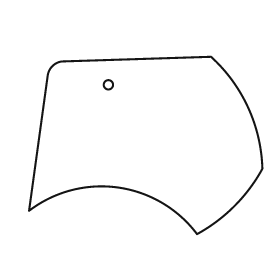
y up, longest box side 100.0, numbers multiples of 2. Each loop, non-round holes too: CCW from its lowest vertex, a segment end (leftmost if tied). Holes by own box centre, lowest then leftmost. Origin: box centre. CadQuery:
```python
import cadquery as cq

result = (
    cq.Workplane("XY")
    .moveTo(22.0, -38.0)
    .threePointArc((38.0, -26.0), (50.0, -10.0))
    .threePointArc((44.0, 16.0), (28.0, 38.0))
    .lineTo(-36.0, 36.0)
    .threePointArc((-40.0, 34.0), (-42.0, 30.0))
    .lineTo(-50.0, -28.0)
    .threePointArc((-12.0, -18.0), (22.0, -38.0))
    .close()
    .moveTo(-16.0, 26.0)
    .circle(2.0)
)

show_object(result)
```